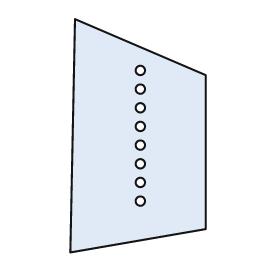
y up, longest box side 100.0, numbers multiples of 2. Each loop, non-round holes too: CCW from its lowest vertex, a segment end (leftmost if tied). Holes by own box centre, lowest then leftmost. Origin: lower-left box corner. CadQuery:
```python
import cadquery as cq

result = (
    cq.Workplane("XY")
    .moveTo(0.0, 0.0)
    .lineTo(58.0, 10.0)
    .lineTo(58.0, 76.0)
    .lineTo(2.0, 100.0)
    .close()
    .moveTo(30.0, 22.0)
    .circle(2.0)
    .moveTo(30.0, 30.0)
    .circle(2.0)
    .moveTo(30.0, 38.0)
    .circle(2.0)
    .moveTo(30.0, 46.0)
    .circle(2.0)
    .moveTo(30.0, 54.0)
    .circle(2.0)
    .moveTo(30.0, 62.0)
    .circle(2.0)
    .moveTo(30.0, 70.0)
    .circle(2.0)
    .moveTo(30.0, 78.0)
    .circle(2.0)
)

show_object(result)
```